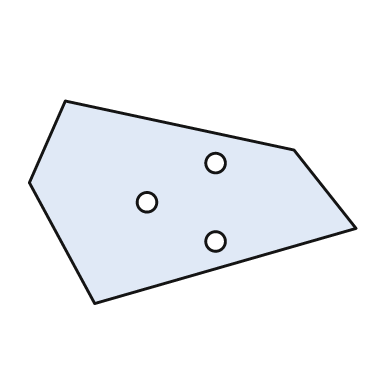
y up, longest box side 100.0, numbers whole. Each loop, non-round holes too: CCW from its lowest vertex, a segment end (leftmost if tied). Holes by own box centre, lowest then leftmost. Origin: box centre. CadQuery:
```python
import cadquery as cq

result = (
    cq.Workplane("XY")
    .moveTo(-30.0, -31.0)
    .lineTo(50.0, -8.0)
    .lineTo(31.0, 16.0)
    .lineTo(-39.0, 31.0)
    .lineTo(-50.0, 6.0)
    .close()
    .moveTo(7.0, -12.0)
    .circle(3.0)
    .moveTo(-14.0, 0.0)
    .circle(3.0)
    .moveTo(7.0, 12.0)
    .circle(3.0)
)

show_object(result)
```